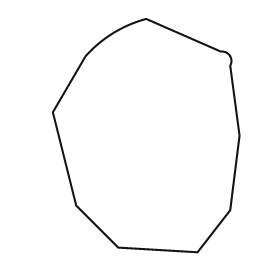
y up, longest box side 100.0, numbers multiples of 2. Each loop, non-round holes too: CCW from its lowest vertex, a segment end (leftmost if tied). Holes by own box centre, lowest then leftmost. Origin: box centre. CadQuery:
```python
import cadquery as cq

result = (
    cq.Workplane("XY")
    .moveTo(22.0, -50.0)
    .lineTo(36.0, -32.0)
    .lineTo(40.0, 0.0)
    .lineTo(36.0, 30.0)
    .threePointArc((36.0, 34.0), (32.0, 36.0))
    .lineTo(0.0, 50.0)
    .threePointArc((-14.0, 44.0), (-26.0, 34.0))
    .lineTo(-40.0, 10.0)
    .lineTo(-30.0, -30.0)
    .lineTo(-12.0, -48.0)
    .close()
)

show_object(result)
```